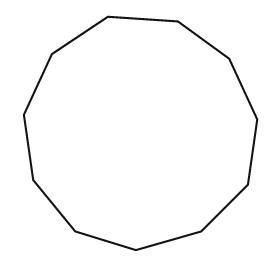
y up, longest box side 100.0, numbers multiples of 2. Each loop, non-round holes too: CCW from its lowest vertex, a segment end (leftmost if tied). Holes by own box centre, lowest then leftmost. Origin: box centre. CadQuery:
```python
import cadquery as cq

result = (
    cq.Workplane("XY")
    .moveTo(-2.0, -50.0)
    .lineTo(26.0, -42.0)
    .lineTo(46.0, -22.0)
    .lineTo(50.0, 6.0)
    .lineTo(38.0, 32.0)
    .lineTo(16.0, 48.0)
    .lineTo(-14.0, 50.0)
    .lineTo(-38.0, 34.0)
    .lineTo(-50.0, 8.0)
    .lineTo(-46.0, -20.0)
    .lineTo(-28.0, -42.0)
    .close()
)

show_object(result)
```